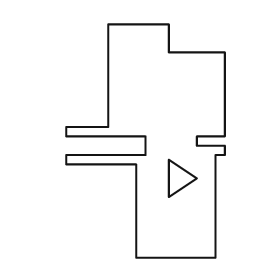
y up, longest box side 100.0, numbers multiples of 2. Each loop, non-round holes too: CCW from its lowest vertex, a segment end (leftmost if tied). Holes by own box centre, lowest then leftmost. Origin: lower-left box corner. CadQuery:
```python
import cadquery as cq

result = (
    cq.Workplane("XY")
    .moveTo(30.0, 0.0)
    .lineTo(64.0, 0.0)
    .lineTo(64.0, 44.0)
    .lineTo(68.0, 44.0)
    .lineTo(68.0, 48.0)
    .lineTo(56.0, 48.0)
    .lineTo(56.0, 52.0)
    .lineTo(68.0, 52.0)
    .lineTo(68.0, 88.0)
    .lineTo(44.0, 88.0)
    .lineTo(44.0, 100.0)
    .lineTo(18.0, 100.0)
    .lineTo(18.0, 56.0)
    .lineTo(0.0, 56.0)
    .lineTo(0.0, 52.0)
    .lineTo(34.0, 52.0)
    .lineTo(34.0, 44.0)
    .lineTo(0.0, 44.0)
    .lineTo(0.0, 40.0)
    .lineTo(30.0, 40.0)
    .close()
    .moveTo(44.0, 26.0)
    .lineTo(56.0, 34.0)
    .lineTo(44.0, 42.0)
    .close()
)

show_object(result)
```